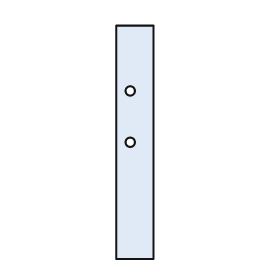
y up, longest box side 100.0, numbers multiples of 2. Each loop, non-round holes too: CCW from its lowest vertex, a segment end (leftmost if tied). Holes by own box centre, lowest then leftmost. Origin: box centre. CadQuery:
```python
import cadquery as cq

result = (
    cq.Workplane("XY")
    .moveTo(-8.0, -50.0)
    .lineTo(8.0, -50.0)
    .lineTo(8.0, 50.0)
    .lineTo(-8.0, 50.0)
    .close()
    .moveTo(-2.0, 0.0)
    .circle(2.0)
    .moveTo(-2.0, 22.0)
    .circle(2.0)
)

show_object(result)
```